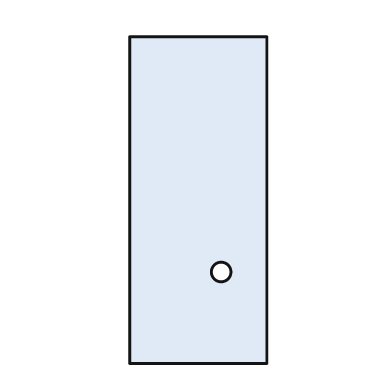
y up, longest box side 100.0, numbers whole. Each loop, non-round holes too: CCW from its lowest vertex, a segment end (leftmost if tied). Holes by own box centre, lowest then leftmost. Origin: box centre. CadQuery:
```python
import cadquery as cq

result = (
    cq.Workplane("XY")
    .moveTo(-21.0, -50.0)
    .lineTo(21.0, -50.0)
    .lineTo(21.0, 50.0)
    .lineTo(-21.0, 50.0)
    .close()
    .moveTo(7.0, -22.0)
    .circle(3.0)
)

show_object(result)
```